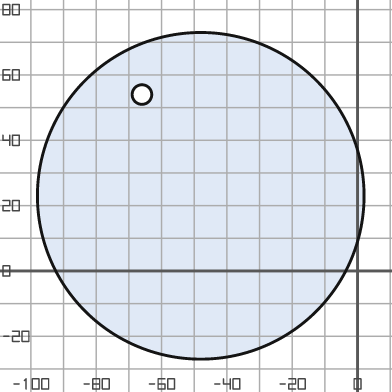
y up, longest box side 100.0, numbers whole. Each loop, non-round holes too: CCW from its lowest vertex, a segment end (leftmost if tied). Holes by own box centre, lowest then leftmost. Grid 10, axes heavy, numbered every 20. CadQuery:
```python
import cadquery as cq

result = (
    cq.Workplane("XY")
    .moveTo(-48.0, 23.0)
    .circle(50.0)
    .moveTo(-66.0, 54.0)
    .circle(3.0)
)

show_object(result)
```